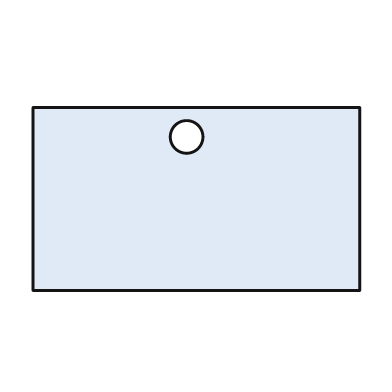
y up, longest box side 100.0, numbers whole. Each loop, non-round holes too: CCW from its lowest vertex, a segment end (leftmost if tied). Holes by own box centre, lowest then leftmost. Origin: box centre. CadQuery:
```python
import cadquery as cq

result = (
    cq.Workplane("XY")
    .moveTo(-50.0, -28.0)
    .lineTo(50.0, -28.0)
    .lineTo(50.0, 28.0)
    .lineTo(-50.0, 28.0)
    .close()
    .moveTo(-3.0, 19.0)
    .circle(5.0)
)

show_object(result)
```